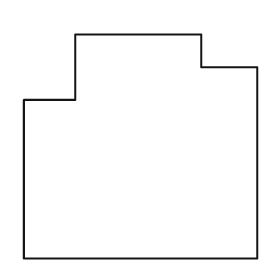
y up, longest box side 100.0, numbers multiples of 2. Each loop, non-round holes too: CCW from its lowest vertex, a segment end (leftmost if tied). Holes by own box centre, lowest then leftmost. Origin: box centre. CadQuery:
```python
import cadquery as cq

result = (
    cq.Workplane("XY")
    .moveTo(-50.0, -48.0)
    .lineTo(50.0, -48.0)
    .lineTo(50.0, 34.0)
    .lineTo(26.0, 34.0)
    .lineTo(26.0, 48.0)
    .lineTo(-28.0, 48.0)
    .lineTo(-28.0, 20.0)
    .lineTo(-50.0, 20.0)
    .close()
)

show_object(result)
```